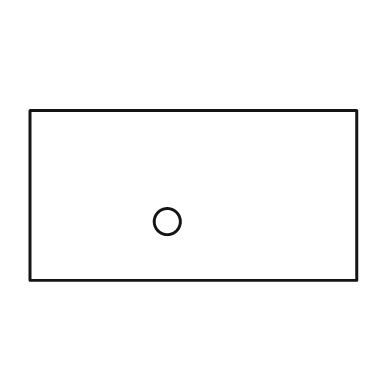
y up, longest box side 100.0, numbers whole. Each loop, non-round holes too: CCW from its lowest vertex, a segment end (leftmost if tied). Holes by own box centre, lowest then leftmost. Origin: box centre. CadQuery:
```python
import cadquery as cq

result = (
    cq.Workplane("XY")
    .moveTo(-50.0, -26.0)
    .lineTo(50.0, -26.0)
    .lineTo(50.0, 26.0)
    .lineTo(-50.0, 26.0)
    .close()
    .moveTo(-8.0, -8.0)
    .circle(4.0)
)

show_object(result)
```